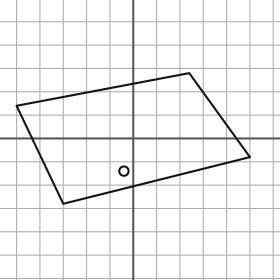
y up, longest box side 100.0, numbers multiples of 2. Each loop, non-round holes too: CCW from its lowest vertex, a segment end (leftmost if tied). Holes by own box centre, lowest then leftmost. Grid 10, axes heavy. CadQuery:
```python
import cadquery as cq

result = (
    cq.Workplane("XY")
    .moveTo(-30.0, -28.0)
    .lineTo(50.0, -8.0)
    .lineTo(24.0, 28.0)
    .lineTo(-50.0, 14.0)
    .close()
    .moveTo(-4.0, -14.0)
    .circle(2.0)
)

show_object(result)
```